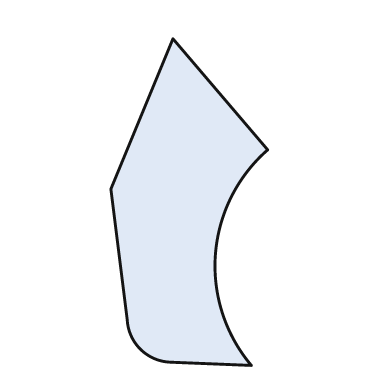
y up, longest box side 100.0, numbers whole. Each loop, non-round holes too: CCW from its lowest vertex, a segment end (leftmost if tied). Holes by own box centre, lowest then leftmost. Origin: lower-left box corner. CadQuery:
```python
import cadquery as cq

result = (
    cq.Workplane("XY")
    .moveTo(43.0, 0.0)
    .threePointArc((32.0, 34.0), (48.0, 66.0))
    .lineTo(19.0, 100.0)
    .lineTo(0.0, 54.0)
    .lineTo(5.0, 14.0)
    .threePointArc((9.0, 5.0), (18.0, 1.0))
    .close()
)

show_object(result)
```